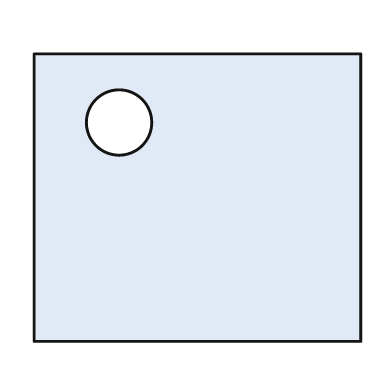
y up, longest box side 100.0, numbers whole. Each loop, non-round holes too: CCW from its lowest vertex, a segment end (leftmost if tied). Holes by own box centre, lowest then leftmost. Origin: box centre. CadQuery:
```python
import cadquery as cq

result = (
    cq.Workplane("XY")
    .moveTo(-50.0, -44.0)
    .lineTo(50.0, -44.0)
    .lineTo(50.0, 44.0)
    .lineTo(-50.0, 44.0)
    .close()
    .moveTo(-24.0, 23.0)
    .circle(10.0)
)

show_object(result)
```